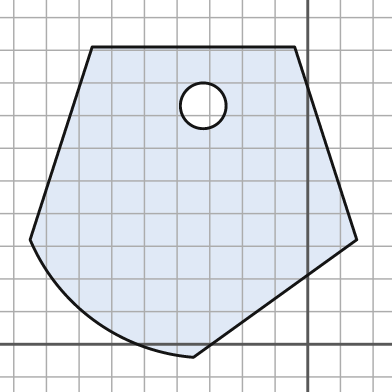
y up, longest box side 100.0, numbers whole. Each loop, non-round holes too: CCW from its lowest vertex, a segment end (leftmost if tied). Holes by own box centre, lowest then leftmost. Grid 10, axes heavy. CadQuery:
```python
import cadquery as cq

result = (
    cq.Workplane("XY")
    .moveTo(-35.0, -4.0)
    .lineTo(15.0, 32.0)
    .lineTo(-4.0, 91.0)
    .lineTo(-66.0, 91.0)
    .lineTo(-85.0, 32.0)
    .threePointArc((-65.0, 7.0), (-35.0, -4.0))
    .close()
    .moveTo(-32.0, 73.0)
    .circle(7.0)
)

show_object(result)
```